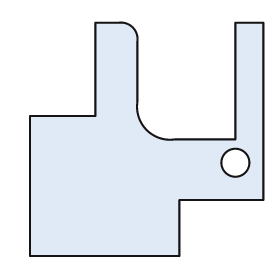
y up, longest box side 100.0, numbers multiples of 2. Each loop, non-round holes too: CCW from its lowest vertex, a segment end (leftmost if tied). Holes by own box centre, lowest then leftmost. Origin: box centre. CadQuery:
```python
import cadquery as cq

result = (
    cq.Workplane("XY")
    .moveTo(-50.0, -50.0)
    .lineTo(14.0, -50.0)
    .lineTo(14.0, -26.0)
    .lineTo(50.0, -26.0)
    .lineTo(50.0, 50.0)
    .lineTo(38.0, 50.0)
    .lineTo(38.0, 0.0)
    .lineTo(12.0, 0.0)
    .threePointArc((0.0, 4.0), (-4.0, 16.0))
    .lineTo(-4.0, 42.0)
    .threePointArc((-6.0, 48.0), (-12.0, 50.0))
    .lineTo(-22.0, 50.0)
    .lineTo(-22.0, 10.0)
    .lineTo(-50.0, 10.0)
    .close()
    .moveTo(38.0, -10.0)
    .circle(6.0)
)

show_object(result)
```